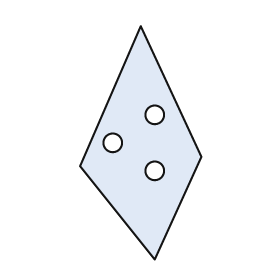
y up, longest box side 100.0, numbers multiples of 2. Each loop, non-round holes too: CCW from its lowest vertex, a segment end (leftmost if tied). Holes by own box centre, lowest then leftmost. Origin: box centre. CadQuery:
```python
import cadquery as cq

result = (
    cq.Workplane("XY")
    .moveTo(6.0, -50.0)
    .lineTo(26.0, -6.0)
    .lineTo(0.0, 50.0)
    .lineTo(-26.0, -10.0)
    .close()
    .moveTo(6.0, -12.0)
    .circle(4.0)
    .moveTo(-12.0, 0.0)
    .circle(4.0)
    .moveTo(6.0, 12.0)
    .circle(4.0)
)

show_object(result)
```